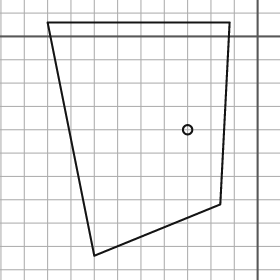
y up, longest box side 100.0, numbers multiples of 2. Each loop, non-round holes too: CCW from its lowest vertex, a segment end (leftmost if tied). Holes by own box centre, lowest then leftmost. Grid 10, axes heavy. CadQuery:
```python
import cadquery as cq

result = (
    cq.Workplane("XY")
    .moveTo(-70.0, -94.0)
    .lineTo(-16.0, -72.0)
    .lineTo(-12.0, 6.0)
    .lineTo(-90.0, 6.0)
    .close()
    .moveTo(-30.0, -40.0)
    .circle(2.0)
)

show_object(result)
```